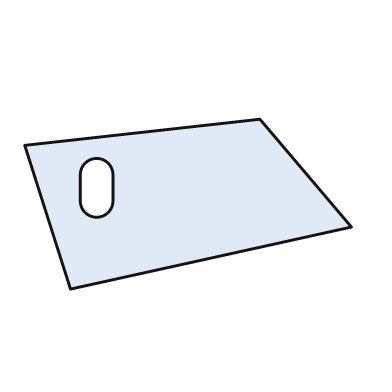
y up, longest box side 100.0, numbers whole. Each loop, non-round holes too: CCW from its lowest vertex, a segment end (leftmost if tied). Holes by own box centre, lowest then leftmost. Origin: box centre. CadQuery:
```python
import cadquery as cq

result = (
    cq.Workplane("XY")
    .moveTo(-36.0, -26.0)
    .lineTo(50.0, -7.0)
    .lineTo(22.0, 26.0)
    .lineTo(-50.0, 18.0)
    .close()
    .moveTo(-33.0, 1.0)
    .threePointArc((-28.0, -4.0), (-23.0, 1.0))
    .lineTo(-23.0, 9.0)
    .threePointArc((-28.0, 14.0), (-33.0, 9.0))
    .close()
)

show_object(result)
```